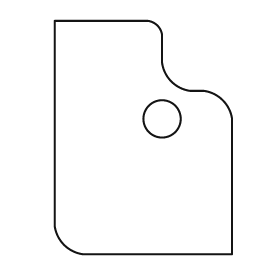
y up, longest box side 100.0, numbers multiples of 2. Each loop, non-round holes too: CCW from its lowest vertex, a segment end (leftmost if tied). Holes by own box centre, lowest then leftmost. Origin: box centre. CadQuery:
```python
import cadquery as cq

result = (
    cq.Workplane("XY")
    .moveTo(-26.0, -50.0)
    .lineTo(38.0, -50.0)
    .lineTo(38.0, 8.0)
    .threePointArc((34.0, 16.0), (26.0, 20.0))
    .lineTo(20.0, 20.0)
    .threePointArc((12.0, 24.0), (8.0, 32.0))
    .lineTo(8.0, 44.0)
    .threePointArc((6.0, 48.0), (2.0, 50.0))
    .lineTo(-38.0, 50.0)
    .lineTo(-38.0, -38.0)
    .threePointArc((-34.0, -46.0), (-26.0, -50.0))
    .close()
    .moveTo(8.0, 8.0)
    .circle(8.0)
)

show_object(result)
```